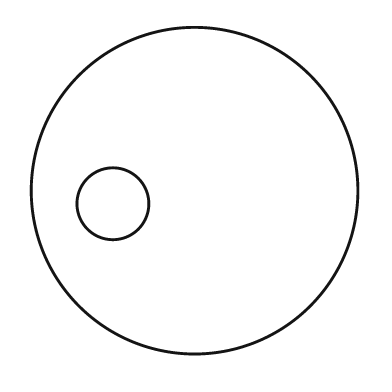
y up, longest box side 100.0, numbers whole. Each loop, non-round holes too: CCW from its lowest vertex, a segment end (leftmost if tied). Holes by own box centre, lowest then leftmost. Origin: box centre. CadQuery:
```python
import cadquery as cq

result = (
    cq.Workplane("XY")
    .moveTo(0.0, 0.0)
    .circle(50.0)
    .moveTo(-25.0, -4.0)
    .circle(11.0)
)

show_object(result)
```